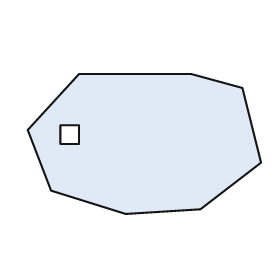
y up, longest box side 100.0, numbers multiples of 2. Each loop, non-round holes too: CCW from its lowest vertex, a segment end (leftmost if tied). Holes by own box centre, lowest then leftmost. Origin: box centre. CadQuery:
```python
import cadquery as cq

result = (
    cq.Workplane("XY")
    .moveTo(-8.0, -30.0)
    .lineTo(24.0, -28.0)
    .lineTo(50.0, -8.0)
    .lineTo(42.0, 24.0)
    .lineTo(20.0, 30.0)
    .lineTo(-28.0, 30.0)
    .lineTo(-50.0, 6.0)
    .lineTo(-40.0, -20.0)
    .close()
    .moveTo(-36.0, 0.0)
    .lineTo(-28.0, 0.0)
    .lineTo(-28.0, 8.0)
    .lineTo(-36.0, 8.0)
    .close()
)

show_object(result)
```